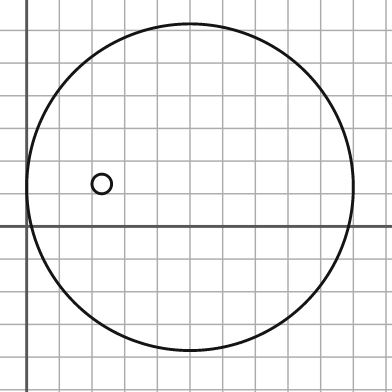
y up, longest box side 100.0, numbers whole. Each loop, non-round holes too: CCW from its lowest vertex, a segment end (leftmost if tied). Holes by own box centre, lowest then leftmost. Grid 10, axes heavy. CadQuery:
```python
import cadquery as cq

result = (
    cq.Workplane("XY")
    .moveTo(50.0, 12.0)
    .circle(50.0)
    .moveTo(23.0, 13.0)
    .circle(3.0)
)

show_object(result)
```